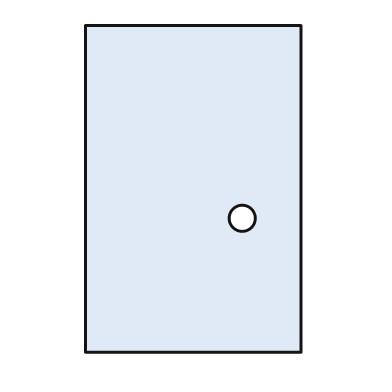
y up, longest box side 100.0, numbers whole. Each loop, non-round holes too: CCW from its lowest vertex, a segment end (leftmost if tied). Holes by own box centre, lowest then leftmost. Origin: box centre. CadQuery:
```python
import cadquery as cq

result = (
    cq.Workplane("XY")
    .moveTo(-33.0, -50.0)
    .lineTo(33.0, -50.0)
    .lineTo(33.0, 50.0)
    .lineTo(-33.0, 50.0)
    .close()
    .moveTo(15.0, -9.0)
    .circle(4.0)
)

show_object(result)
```